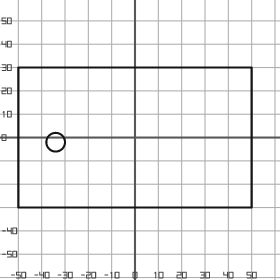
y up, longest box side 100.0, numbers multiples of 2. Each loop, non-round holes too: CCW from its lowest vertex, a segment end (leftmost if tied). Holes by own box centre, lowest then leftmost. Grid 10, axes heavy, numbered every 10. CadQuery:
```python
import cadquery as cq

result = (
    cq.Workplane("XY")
    .moveTo(-50.0, -30.0)
    .lineTo(50.0, -30.0)
    .lineTo(50.0, 30.0)
    .lineTo(-50.0, 30.0)
    .close()
    .moveTo(-34.0, -2.0)
    .circle(4.0)
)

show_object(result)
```